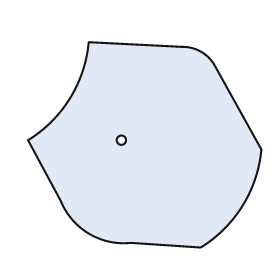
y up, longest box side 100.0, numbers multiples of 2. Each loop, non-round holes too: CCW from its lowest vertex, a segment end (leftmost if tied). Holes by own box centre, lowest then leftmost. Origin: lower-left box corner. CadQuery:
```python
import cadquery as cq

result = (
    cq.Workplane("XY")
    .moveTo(74.0, 0.0)
    .threePointArc((92.0, 18.0), (100.0, 42.0))
    .lineTo(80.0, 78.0)
    .threePointArc((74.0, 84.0), (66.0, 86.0))
    .lineTo(26.0, 88.0)
    .threePointArc((18.0, 64.0), (0.0, 46.0))
    .lineTo(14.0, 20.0)
    .threePointArc((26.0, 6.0), (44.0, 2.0))
    .close()
    .moveTo(40.0, 46.0)
    .circle(2.0)
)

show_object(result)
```